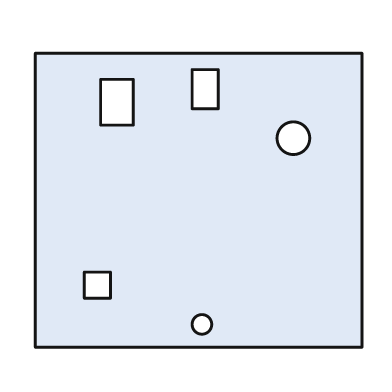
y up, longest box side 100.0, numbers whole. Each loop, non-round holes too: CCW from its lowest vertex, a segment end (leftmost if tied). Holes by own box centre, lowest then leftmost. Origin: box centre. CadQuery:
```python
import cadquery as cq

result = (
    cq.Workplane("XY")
    .moveTo(-50.0, -45.0)
    .lineTo(50.0, -45.0)
    .lineTo(50.0, 45.0)
    .lineTo(-50.0, 45.0)
    .close()
    .moveTo(1.0, -38.0)
    .circle(3.0)
    .moveTo(-35.0, -30.0)
    .lineTo(-27.0, -30.0)
    .lineTo(-27.0, -22.0)
    .lineTo(-35.0, -22.0)
    .close()
    .moveTo(29.0, 19.0)
    .circle(5.0)
    .moveTo(-30.0, 23.0)
    .lineTo(-20.0, 23.0)
    .lineTo(-20.0, 37.0)
    .lineTo(-30.0, 37.0)
    .close()
    .moveTo(-2.0, 28.0)
    .lineTo(6.0, 28.0)
    .lineTo(6.0, 40.0)
    .lineTo(-2.0, 40.0)
    .close()
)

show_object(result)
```